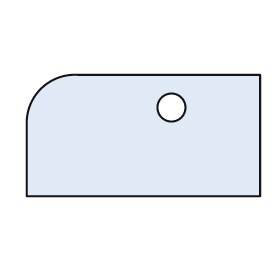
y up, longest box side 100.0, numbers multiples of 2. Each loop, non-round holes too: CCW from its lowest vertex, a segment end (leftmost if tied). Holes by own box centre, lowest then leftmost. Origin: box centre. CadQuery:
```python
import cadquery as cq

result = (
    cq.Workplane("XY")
    .moveTo(-50.0, -26.0)
    .lineTo(50.0, -26.0)
    .lineTo(50.0, 26.0)
    .lineTo(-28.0, 26.0)
    .threePointArc((-44.0, 20.0), (-50.0, 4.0))
    .close()
    .moveTo(12.0, 12.0)
    .circle(6.0)
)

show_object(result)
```